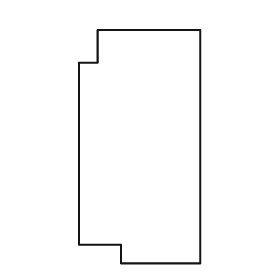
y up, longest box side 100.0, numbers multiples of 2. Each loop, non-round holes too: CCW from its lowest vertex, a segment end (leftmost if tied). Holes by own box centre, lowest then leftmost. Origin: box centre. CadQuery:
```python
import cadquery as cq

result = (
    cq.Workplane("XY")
    .moveTo(-8.0, -50.0)
    .lineTo(26.0, -50.0)
    .lineTo(26.0, 50.0)
    .lineTo(-18.0, 50.0)
    .lineTo(-18.0, 36.0)
    .lineTo(-26.0, 36.0)
    .lineTo(-26.0, -42.0)
    .lineTo(-8.0, -42.0)
    .close()
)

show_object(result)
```